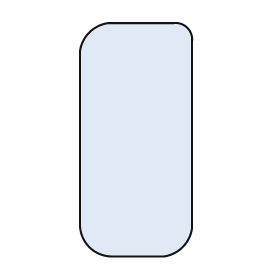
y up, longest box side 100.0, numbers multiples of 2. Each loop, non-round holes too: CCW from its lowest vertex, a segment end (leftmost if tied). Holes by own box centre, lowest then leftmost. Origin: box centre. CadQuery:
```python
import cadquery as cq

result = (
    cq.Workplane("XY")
    .moveTo(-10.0, -50.0)
    .lineTo(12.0, -50.0)
    .threePointArc((20.0, -46.0), (24.0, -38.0))
    .lineTo(24.0, 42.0)
    .threePointArc((22.0, 48.0), (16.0, 50.0))
    .lineTo(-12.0, 50.0)
    .threePointArc((-20.0, 46.0), (-24.0, 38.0))
    .lineTo(-24.0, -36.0)
    .threePointArc((-20.0, -46.0), (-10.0, -50.0))
    .close()
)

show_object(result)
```